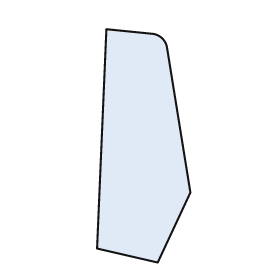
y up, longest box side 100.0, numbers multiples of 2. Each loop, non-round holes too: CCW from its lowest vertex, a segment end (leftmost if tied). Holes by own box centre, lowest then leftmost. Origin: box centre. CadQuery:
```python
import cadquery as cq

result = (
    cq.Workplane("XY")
    .moveTo(6.0, -50.0)
    .lineTo(20.0, -20.0)
    .lineTo(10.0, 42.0)
    .threePointArc((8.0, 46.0), (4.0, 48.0))
    .lineTo(-16.0, 50.0)
    .lineTo(-20.0, -44.0)
    .close()
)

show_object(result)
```